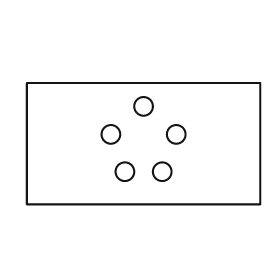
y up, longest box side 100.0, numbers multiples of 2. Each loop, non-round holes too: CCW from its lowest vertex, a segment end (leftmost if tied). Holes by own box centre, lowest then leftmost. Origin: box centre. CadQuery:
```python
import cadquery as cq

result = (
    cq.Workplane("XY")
    .moveTo(-50.0, -26.0)
    .lineTo(50.0, -26.0)
    .lineTo(50.0, 26.0)
    .lineTo(-50.0, 26.0)
    .close()
    .moveTo(-8.0, -12.0)
    .circle(4.0)
    .moveTo(8.0, -12.0)
    .circle(4.0)
    .moveTo(-14.0, 4.0)
    .circle(4.0)
    .moveTo(14.0, 4.0)
    .circle(4.0)
    .moveTo(0.0, 16.0)
    .circle(4.0)
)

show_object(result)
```